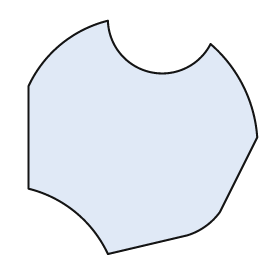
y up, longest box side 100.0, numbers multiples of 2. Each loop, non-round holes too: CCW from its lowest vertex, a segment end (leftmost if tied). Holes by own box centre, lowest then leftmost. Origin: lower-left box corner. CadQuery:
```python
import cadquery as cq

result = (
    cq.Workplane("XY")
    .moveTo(34.0, 0.0)
    .lineTo(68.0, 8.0)
    .threePointArc((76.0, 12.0), (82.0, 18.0))
    .lineTo(98.0, 50.0)
    .threePointArc((92.0, 72.0), (78.0, 90.0))
    .threePointArc((52.0, 78.0), (34.0, 100.0))
    .threePointArc((14.0, 90.0), (0.0, 72.0))
    .lineTo(0.0, 28.0)
    .threePointArc((20.0, 18.0), (34.0, 0.0))
    .close()
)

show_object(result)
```